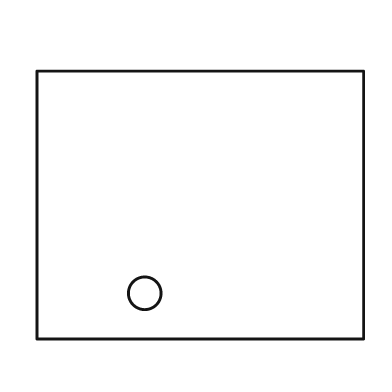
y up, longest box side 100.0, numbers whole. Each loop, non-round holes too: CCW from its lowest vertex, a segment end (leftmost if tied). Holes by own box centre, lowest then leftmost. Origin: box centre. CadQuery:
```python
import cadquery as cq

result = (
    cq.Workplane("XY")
    .moveTo(-50.0, -41.0)
    .lineTo(50.0, -41.0)
    .lineTo(50.0, 41.0)
    .lineTo(-50.0, 41.0)
    .close()
    .moveTo(-17.0, -27.0)
    .circle(5.0)
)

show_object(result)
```